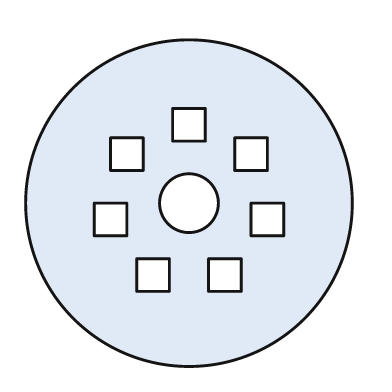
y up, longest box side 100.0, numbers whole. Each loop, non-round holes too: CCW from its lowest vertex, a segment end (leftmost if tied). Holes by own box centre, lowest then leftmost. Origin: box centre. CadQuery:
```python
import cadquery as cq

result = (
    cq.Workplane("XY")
    .moveTo(0.0, 0.0)
    .circle(50.0)
    .moveTo(-16.0, -27.0)
    .lineTo(-6.0, -27.0)
    .lineTo(-6.0, -17.0)
    .lineTo(-16.0, -17.0)
    .close()
    .moveTo(6.0, -27.0)
    .lineTo(16.0, -27.0)
    .lineTo(16.0, -17.0)
    .lineTo(6.0, -17.0)
    .close()
    .moveTo(-29.0, -10.0)
    .lineTo(-19.0, -10.0)
    .lineTo(-19.0, 0.0)
    .lineTo(-29.0, 0.0)
    .close()
    .moveTo(19.0, -10.0)
    .lineTo(29.0, -10.0)
    .lineTo(29.0, 0.0)
    .lineTo(19.0, 0.0)
    .close()
    .moveTo(0.0, 0.0)
    .circle(9.0)
    .moveTo(-24.0, 10.0)
    .lineTo(-14.0, 10.0)
    .lineTo(-14.0, 20.0)
    .lineTo(-24.0, 20.0)
    .close()
    .moveTo(14.0, 10.0)
    .lineTo(24.0, 10.0)
    .lineTo(24.0, 20.0)
    .lineTo(14.0, 20.0)
    .close()
    .moveTo(-5.0, 19.0)
    .lineTo(5.0, 19.0)
    .lineTo(5.0, 29.0)
    .lineTo(-5.0, 29.0)
    .close()
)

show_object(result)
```